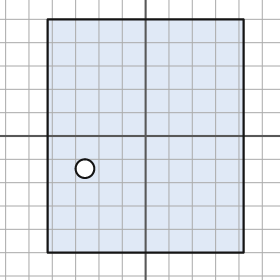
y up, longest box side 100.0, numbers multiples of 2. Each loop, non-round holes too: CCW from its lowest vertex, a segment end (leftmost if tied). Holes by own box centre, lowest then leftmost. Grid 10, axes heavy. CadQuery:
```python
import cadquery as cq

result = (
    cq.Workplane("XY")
    .moveTo(-42.0, -50.0)
    .lineTo(42.0, -50.0)
    .lineTo(42.0, 50.0)
    .lineTo(-42.0, 50.0)
    .close()
    .moveTo(-26.0, -14.0)
    .circle(4.0)
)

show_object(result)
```